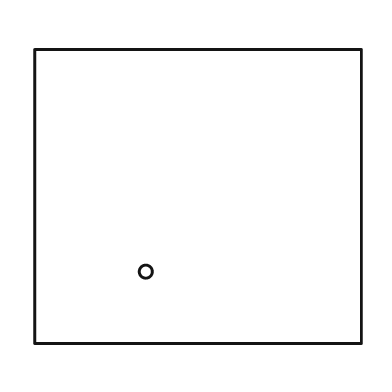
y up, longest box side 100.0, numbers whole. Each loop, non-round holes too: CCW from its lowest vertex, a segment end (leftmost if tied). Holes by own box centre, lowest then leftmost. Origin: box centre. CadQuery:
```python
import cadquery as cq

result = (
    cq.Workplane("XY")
    .moveTo(-50.0, -45.0)
    .lineTo(50.0, -45.0)
    .lineTo(50.0, 45.0)
    .lineTo(-50.0, 45.0)
    .close()
    .moveTo(-16.0, -23.0)
    .circle(2.0)
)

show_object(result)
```